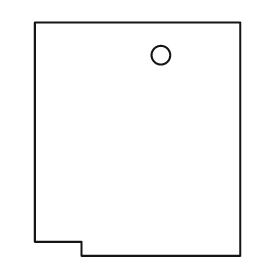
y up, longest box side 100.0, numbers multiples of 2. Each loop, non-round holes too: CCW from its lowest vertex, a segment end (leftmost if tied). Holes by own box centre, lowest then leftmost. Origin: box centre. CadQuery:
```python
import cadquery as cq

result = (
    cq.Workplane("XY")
    .moveTo(-24.0, -50.0)
    .lineTo(44.0, -50.0)
    .lineTo(44.0, 50.0)
    .lineTo(-44.0, 50.0)
    .lineTo(-44.0, -44.0)
    .lineTo(-24.0, -44.0)
    .close()
    .moveTo(10.0, 36.0)
    .circle(4.0)
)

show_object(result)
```